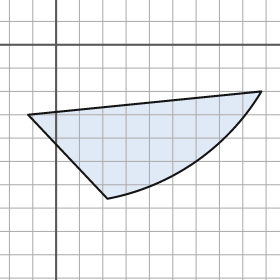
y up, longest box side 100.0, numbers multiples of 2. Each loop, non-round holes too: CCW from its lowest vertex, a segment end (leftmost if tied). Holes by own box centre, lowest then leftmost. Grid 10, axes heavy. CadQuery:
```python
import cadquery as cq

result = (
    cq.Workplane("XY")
    .moveTo(22.0, -66.0)
    .threePointArc((60.0, -50.0), (88.0, -20.0))
    .lineTo(-12.0, -30.0)
    .close()
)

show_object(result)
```